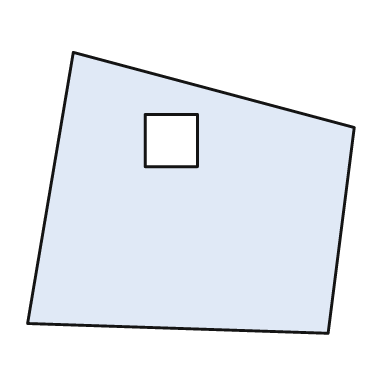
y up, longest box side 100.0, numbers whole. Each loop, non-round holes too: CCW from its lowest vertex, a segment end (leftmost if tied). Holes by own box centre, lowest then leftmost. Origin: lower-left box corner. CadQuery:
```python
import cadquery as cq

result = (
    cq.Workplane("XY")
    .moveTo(92.0, 0.0)
    .lineTo(100.0, 63.0)
    .lineTo(14.0, 86.0)
    .lineTo(0.0, 3.0)
    .close()
    .moveTo(36.0, 51.0)
    .lineTo(52.0, 51.0)
    .lineTo(52.0, 67.0)
    .lineTo(36.0, 67.0)
    .close()
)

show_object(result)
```